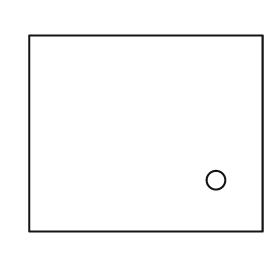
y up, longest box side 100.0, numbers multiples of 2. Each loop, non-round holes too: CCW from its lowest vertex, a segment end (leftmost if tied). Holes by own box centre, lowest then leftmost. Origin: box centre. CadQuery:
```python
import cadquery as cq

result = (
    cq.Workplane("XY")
    .moveTo(-50.0, -42.0)
    .lineTo(50.0, -42.0)
    .lineTo(50.0, 42.0)
    .lineTo(-50.0, 42.0)
    .close()
    .moveTo(30.0, -20.0)
    .circle(4.0)
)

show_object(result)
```